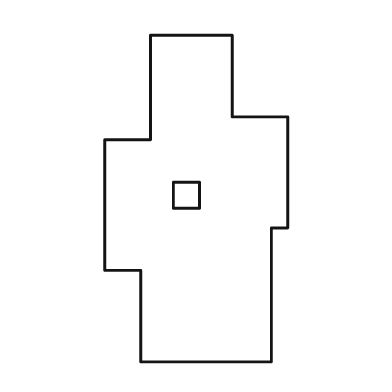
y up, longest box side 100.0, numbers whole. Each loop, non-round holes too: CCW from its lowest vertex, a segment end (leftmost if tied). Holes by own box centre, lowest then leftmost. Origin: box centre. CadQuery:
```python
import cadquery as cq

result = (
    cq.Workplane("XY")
    .moveTo(-17.0, -50.0)
    .lineTo(23.0, -50.0)
    .lineTo(23.0, -9.0)
    .lineTo(28.0, -9.0)
    .lineTo(28.0, 25.0)
    .lineTo(11.0, 25.0)
    .lineTo(11.0, 50.0)
    .lineTo(-14.0, 50.0)
    .lineTo(-14.0, 18.0)
    .lineTo(-28.0, 18.0)
    .lineTo(-28.0, -22.0)
    .lineTo(-17.0, -22.0)
    .close()
    .moveTo(-7.0, -3.0)
    .lineTo(1.0, -3.0)
    .lineTo(1.0, 5.0)
    .lineTo(-7.0, 5.0)
    .close()
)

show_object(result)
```